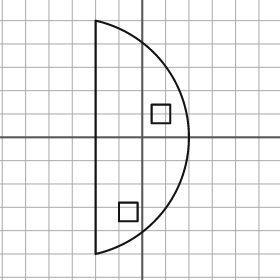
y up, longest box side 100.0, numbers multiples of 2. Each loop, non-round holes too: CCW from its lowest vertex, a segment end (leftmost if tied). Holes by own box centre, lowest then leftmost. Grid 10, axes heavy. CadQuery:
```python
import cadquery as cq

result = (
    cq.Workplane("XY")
    .moveTo(-20.0, -50.0)
    .threePointArc((20.0, 0.0), (-20.0, 50.0))
    .close()
    .moveTo(-10.0, -36.0)
    .lineTo(-2.0, -36.0)
    .lineTo(-2.0, -28.0)
    .lineTo(-10.0, -28.0)
    .close()
    .moveTo(4.0, 6.0)
    .lineTo(12.0, 6.0)
    .lineTo(12.0, 14.0)
    .lineTo(4.0, 14.0)
    .close()
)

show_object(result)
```